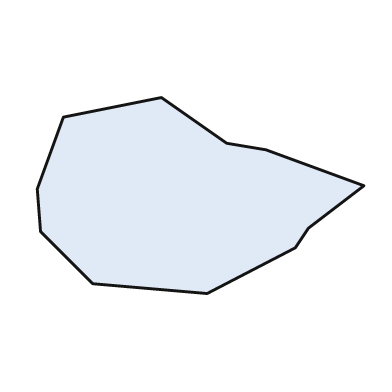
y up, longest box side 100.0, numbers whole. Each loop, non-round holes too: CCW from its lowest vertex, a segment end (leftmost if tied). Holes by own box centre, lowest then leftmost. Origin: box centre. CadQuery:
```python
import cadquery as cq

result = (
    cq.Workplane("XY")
    .moveTo(2.0, -30.0)
    .lineTo(29.0, -16.0)
    .lineTo(33.0, -10.0)
    .lineTo(50.0, 3.0)
    .lineTo(20.0, 14.0)
    .lineTo(8.0, 16.0)
    .lineTo(-12.0, 30.0)
    .lineTo(-42.0, 24.0)
    .lineTo(-50.0, 2.0)
    .lineTo(-49.0, -11.0)
    .lineTo(-33.0, -27.0)
    .close()
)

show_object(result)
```